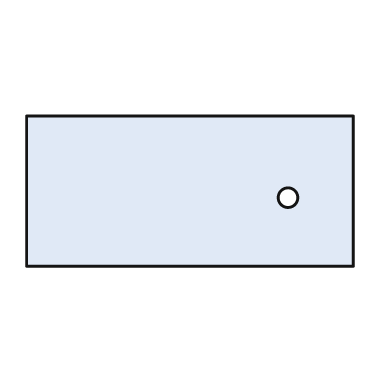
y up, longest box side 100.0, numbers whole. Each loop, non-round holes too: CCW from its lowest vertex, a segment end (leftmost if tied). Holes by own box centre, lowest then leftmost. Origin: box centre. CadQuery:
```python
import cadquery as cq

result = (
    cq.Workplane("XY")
    .moveTo(-50.0, -23.0)
    .lineTo(50.0, -23.0)
    .lineTo(50.0, 23.0)
    .lineTo(-50.0, 23.0)
    .close()
    .moveTo(30.0, -2.0)
    .circle(3.0)
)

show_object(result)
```